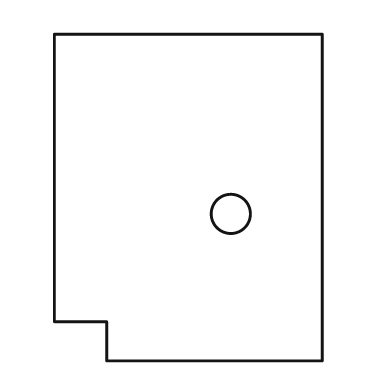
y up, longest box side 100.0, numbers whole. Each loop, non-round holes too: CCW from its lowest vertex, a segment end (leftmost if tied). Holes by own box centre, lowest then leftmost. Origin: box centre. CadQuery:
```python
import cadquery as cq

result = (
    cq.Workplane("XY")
    .moveTo(-25.0, -50.0)
    .lineTo(41.0, -50.0)
    .lineTo(41.0, 50.0)
    .lineTo(-41.0, 50.0)
    .lineTo(-41.0, -38.0)
    .lineTo(-25.0, -38.0)
    .close()
    .moveTo(13.0, -5.0)
    .circle(6.0)
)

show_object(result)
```